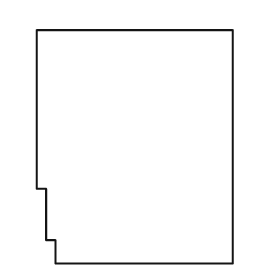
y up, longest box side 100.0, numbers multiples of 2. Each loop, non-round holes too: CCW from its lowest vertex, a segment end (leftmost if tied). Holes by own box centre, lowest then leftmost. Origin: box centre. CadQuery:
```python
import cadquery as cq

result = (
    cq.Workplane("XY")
    .moveTo(-34.0, -50.0)
    .lineTo(42.0, -50.0)
    .lineTo(42.0, 50.0)
    .lineTo(-42.0, 50.0)
    .lineTo(-42.0, -18.0)
    .lineTo(-38.0, -18.0)
    .lineTo(-38.0, -40.0)
    .lineTo(-34.0, -40.0)
    .close()
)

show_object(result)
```